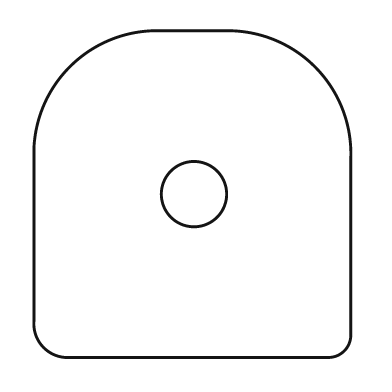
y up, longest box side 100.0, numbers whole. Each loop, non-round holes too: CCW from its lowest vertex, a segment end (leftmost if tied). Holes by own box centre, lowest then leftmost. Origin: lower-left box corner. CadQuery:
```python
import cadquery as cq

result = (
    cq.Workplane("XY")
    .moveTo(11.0, 0.0)
    .lineTo(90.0, 0.0)
    .threePointArc((95.0, 2.0), (97.0, 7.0))
    .lineTo(97.0, 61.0)
    .threePointArc((86.0, 89.0), (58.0, 100.0))
    .lineTo(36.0, 100.0)
    .threePointArc((11.0, 89.0), (0.0, 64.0))
    .lineTo(0.0, 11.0)
    .threePointArc((3.0, 3.0), (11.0, 0.0))
    .close()
    .moveTo(49.0, 50.0)
    .circle(10.0)
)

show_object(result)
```